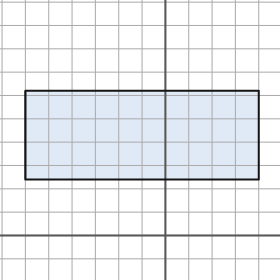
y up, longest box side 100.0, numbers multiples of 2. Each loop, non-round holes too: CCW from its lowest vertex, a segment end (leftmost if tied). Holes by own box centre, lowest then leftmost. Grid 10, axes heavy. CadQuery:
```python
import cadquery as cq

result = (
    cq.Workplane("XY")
    .moveTo(-60.0, 24.0)
    .lineTo(40.0, 24.0)
    .lineTo(40.0, 62.0)
    .lineTo(-60.0, 62.0)
    .close()
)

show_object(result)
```